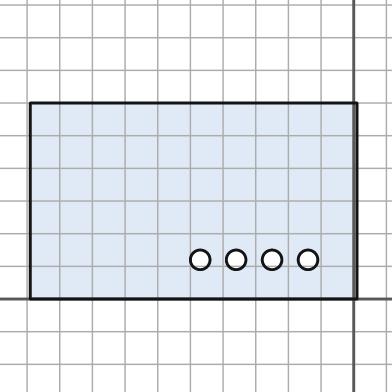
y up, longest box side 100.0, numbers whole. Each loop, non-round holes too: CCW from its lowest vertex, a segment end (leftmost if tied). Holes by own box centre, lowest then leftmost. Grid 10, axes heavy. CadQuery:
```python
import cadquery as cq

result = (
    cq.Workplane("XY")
    .moveTo(-99.0, 0.0)
    .lineTo(1.0, 0.0)
    .lineTo(1.0, 60.0)
    .lineTo(-99.0, 60.0)
    .close()
    .moveTo(-47.0, 12.0)
    .circle(3.0)
    .moveTo(-36.0, 12.0)
    .circle(3.0)
    .moveTo(-25.0, 12.0)
    .circle(3.0)
    .moveTo(-14.0, 12.0)
    .circle(3.0)
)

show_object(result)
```